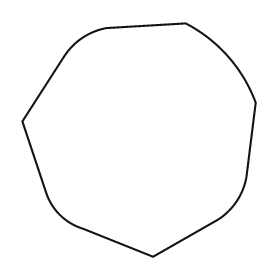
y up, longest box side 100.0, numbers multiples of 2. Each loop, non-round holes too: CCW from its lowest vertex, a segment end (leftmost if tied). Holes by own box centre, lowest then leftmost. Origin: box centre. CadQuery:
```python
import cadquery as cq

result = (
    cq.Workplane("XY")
    .moveTo(6.0, -50.0)
    .lineTo(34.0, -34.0)
    .threePointArc((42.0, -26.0), (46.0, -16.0))
    .lineTo(50.0, 16.0)
    .threePointArc((38.0, 36.0), (20.0, 50.0))
    .lineTo(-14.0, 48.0)
    .threePointArc((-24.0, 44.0), (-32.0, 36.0))
    .lineTo(-50.0, 8.0)
    .lineTo(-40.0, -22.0)
    .threePointArc((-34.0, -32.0), (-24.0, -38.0))
    .close()
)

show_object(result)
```